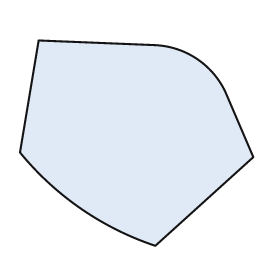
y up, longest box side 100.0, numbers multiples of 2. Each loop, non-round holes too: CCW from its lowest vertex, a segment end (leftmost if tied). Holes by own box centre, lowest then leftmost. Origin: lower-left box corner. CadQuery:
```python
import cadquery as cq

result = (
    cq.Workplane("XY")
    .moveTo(58.0, 0.0)
    .lineTo(100.0, 38.0)
    .lineTo(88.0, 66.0)
    .threePointArc((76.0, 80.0), (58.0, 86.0))
    .lineTo(8.0, 88.0)
    .lineTo(0.0, 40.0)
    .threePointArc((26.0, 16.0), (58.0, 0.0))
    .close()
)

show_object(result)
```